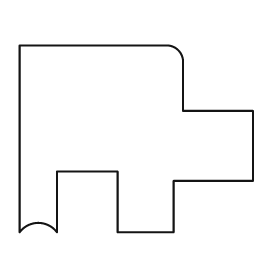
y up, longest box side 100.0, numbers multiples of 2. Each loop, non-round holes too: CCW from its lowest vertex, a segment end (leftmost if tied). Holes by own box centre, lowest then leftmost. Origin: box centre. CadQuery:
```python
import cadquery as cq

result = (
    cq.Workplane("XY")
    .moveTo(-50.0, -40.0)
    .threePointArc((-42.0, -36.0), (-34.0, -40.0))
    .lineTo(-34.0, -14.0)
    .lineTo(-8.0, -14.0)
    .lineTo(-8.0, -40.0)
    .lineTo(16.0, -40.0)
    .lineTo(16.0, -18.0)
    .lineTo(50.0, -18.0)
    .lineTo(50.0, 12.0)
    .lineTo(20.0, 12.0)
    .lineTo(20.0, 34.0)
    .threePointArc((18.0, 38.0), (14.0, 40.0))
    .lineTo(-50.0, 40.0)
    .close()
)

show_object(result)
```